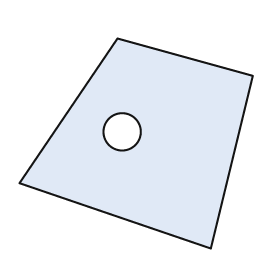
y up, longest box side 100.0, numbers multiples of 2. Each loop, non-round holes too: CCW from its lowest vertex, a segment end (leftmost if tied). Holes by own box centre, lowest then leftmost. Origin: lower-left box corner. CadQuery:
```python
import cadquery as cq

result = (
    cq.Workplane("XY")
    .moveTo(82.0, 0.0)
    .lineTo(100.0, 74.0)
    .lineTo(42.0, 90.0)
    .lineTo(0.0, 28.0)
    .close()
    .moveTo(44.0, 50.0)
    .circle(8.0)
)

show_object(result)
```